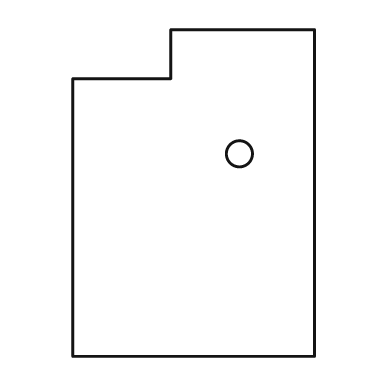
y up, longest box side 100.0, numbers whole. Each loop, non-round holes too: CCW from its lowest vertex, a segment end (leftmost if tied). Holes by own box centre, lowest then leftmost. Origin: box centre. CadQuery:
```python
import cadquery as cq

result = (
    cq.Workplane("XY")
    .moveTo(-37.0, -50.0)
    .lineTo(37.0, -50.0)
    .lineTo(37.0, 50.0)
    .lineTo(-7.0, 50.0)
    .lineTo(-7.0, 35.0)
    .lineTo(-37.0, 35.0)
    .close()
    .moveTo(14.0, 12.0)
    .circle(4.0)
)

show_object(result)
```